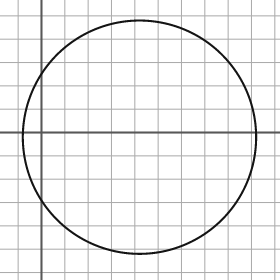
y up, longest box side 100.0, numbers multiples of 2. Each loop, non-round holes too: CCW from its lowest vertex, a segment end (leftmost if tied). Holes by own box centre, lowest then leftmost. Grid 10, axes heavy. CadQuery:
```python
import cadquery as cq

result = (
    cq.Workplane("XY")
    .moveTo(42.0, -2.0)
    .circle(50.0)
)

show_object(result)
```